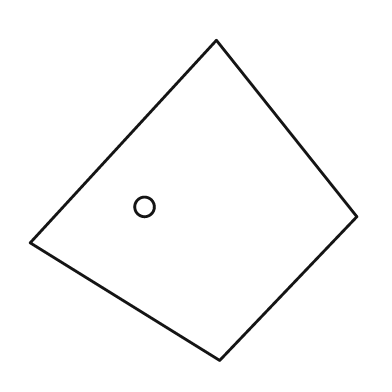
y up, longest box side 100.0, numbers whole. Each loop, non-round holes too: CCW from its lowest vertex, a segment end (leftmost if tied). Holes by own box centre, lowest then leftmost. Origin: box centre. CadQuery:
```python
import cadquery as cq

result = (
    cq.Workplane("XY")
    .moveTo(8.0, -49.0)
    .lineTo(50.0, -5.0)
    .lineTo(7.0, 49.0)
    .lineTo(-50.0, -13.0)
    .close()
    .moveTo(-15.0, -2.0)
    .circle(3.0)
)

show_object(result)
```